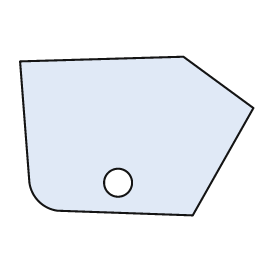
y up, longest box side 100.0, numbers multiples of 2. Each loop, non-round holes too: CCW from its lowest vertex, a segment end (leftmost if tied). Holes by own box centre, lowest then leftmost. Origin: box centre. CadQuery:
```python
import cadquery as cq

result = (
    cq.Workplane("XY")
    .moveTo(24.0, -34.0)
    .lineTo(50.0, 12.0)
    .lineTo(20.0, 34.0)
    .lineTo(-50.0, 32.0)
    .lineTo(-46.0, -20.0)
    .threePointArc((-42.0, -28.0), (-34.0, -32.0))
    .close()
    .moveTo(-8.0, -20.0)
    .circle(6.0)
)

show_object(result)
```